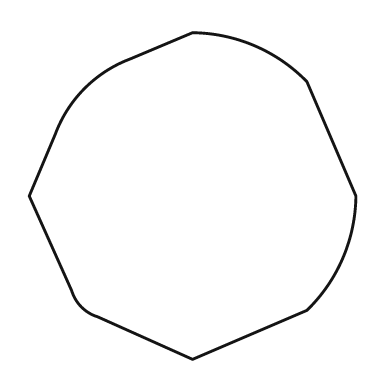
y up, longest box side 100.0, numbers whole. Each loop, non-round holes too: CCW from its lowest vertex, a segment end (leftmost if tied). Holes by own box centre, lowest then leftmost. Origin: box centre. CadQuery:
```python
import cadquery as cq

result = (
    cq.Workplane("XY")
    .moveTo(0.0, -50.0)
    .lineTo(35.0, -35.0)
    .threePointArc((46.0, -19.0), (50.0, 0.0))
    .lineTo(35.0, 35.0)
    .threePointArc((19.0, 46.0), (0.0, 50.0))
    .lineTo(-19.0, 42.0)
    .threePointArc((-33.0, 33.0), (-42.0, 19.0))
    .lineTo(-50.0, 0.0)
    .lineTo(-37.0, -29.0)
    .threePointArc((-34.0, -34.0), (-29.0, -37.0))
    .close()
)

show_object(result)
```